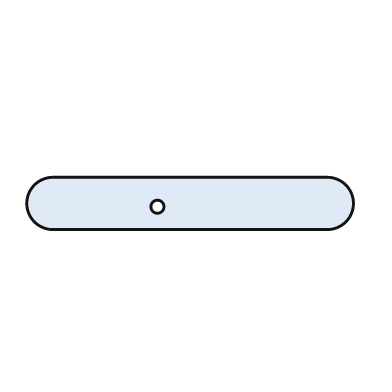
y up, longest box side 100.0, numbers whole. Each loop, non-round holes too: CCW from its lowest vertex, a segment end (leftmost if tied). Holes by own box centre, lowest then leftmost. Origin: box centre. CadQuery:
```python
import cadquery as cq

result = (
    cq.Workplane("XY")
    .moveTo(-42.0, -8.0)
    .lineTo(42.0, -8.0)
    .threePointArc((50.0, 0.0), (42.0, 8.0))
    .lineTo(-42.0, 8.0)
    .threePointArc((-50.0, 0.0), (-42.0, -8.0))
    .close()
    .moveTo(-10.0, -1.0)
    .circle(2.0)
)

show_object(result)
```